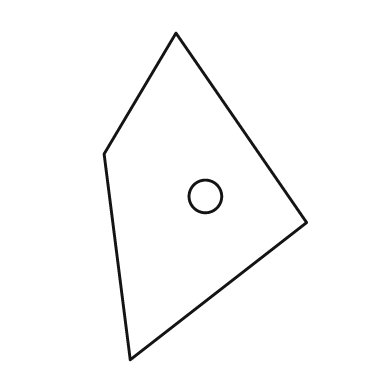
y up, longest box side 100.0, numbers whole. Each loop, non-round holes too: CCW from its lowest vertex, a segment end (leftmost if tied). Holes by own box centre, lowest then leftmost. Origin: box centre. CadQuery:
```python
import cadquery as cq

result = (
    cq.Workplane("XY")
    .moveTo(-23.0, -50.0)
    .lineTo(31.0, -8.0)
    .lineTo(-9.0, 50.0)
    .lineTo(-31.0, 13.0)
    .close()
    .moveTo(0.0, 0.0)
    .circle(5.0)
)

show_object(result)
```